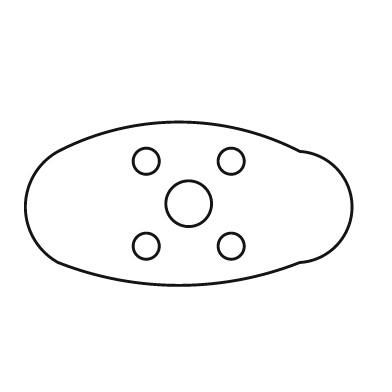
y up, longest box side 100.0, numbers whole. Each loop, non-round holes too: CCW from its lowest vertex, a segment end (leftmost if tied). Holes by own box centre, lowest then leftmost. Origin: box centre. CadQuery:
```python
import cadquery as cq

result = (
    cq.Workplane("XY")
    .moveTo(-40.0, -18.0)
    .threePointArc((-3.0, -25.0), (34.0, -18.0))
    .threePointArc((50.0, -1.0), (34.0, 16.0))
    .threePointArc((-3.0, 25.0), (-40.0, 16.0))
    .threePointArc((-50.0, -1.0), (-40.0, -18.0))
    .close()
    .moveTo(-13.0, -13.0)
    .circle(4.0)
    .moveTo(13.0, -13.0)
    .circle(4.0)
    .moveTo(0.0, 0.0)
    .circle(7.0)
    .moveTo(-13.0, 13.0)
    .circle(4.0)
    .moveTo(13.0, 13.0)
    .circle(4.0)
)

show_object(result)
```